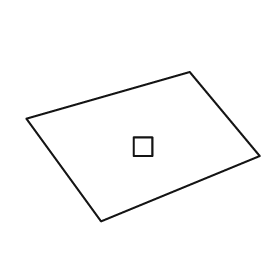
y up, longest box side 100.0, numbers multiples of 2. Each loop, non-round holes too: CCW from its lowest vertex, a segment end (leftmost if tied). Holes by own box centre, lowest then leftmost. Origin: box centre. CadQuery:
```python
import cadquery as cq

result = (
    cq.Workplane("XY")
    .moveTo(-18.0, -32.0)
    .lineTo(50.0, -4.0)
    .lineTo(20.0, 32.0)
    .lineTo(-50.0, 12.0)
    .close()
    .moveTo(-4.0, -4.0)
    .lineTo(4.0, -4.0)
    .lineTo(4.0, 4.0)
    .lineTo(-4.0, 4.0)
    .close()
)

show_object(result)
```